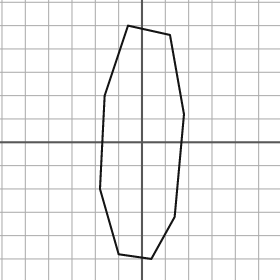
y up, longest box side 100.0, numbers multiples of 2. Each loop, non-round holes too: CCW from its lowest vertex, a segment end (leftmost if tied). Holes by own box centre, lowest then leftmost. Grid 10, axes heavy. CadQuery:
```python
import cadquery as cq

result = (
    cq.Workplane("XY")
    .moveTo(4.0, -50.0)
    .lineTo(14.0, -32.0)
    .lineTo(18.0, 12.0)
    .lineTo(12.0, 46.0)
    .lineTo(-6.0, 50.0)
    .lineTo(-16.0, 20.0)
    .lineTo(-18.0, -20.0)
    .lineTo(-10.0, -48.0)
    .close()
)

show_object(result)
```